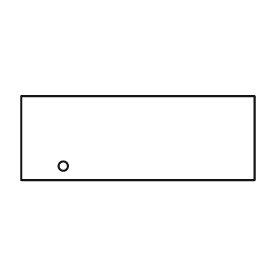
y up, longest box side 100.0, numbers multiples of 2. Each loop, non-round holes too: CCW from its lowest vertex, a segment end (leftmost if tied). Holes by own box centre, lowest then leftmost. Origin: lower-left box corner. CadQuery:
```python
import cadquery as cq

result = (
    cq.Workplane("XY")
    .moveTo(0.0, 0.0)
    .lineTo(100.0, 0.0)
    .lineTo(100.0, 36.0)
    .lineTo(0.0, 36.0)
    .close()
    .moveTo(18.0, 6.0)
    .circle(2.0)
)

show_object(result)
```